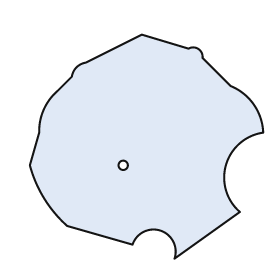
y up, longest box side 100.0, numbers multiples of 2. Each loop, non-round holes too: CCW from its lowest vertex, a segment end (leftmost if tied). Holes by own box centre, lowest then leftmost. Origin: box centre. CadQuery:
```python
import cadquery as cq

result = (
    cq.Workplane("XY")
    .moveTo(12.0, -48.0)
    .lineTo(40.0, -28.0)
    .threePointArc((34.0, -8.0), (50.0, 6.0))
    .threePointArc((46.0, 18.0), (36.0, 26.0))
    .lineTo(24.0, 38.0)
    .threePointArc((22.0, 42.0), (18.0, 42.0))
    .lineTo(-2.0, 48.0)
    .lineTo(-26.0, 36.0)
    .threePointArc((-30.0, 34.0), (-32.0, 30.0))
    .lineTo(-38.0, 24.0)
    .threePointArc((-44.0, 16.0), (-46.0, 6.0))
    .lineTo(-50.0, -8.0)
    .threePointArc((-44.0, -22.0), (-34.0, -34.0))
    .lineTo(-6.0, -42.0)
    .threePointArc((6.0, -36.0), (12.0, -48.0))
    .close()
    .moveTo(-10.0, -8.0)
    .circle(2.0)
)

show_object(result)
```